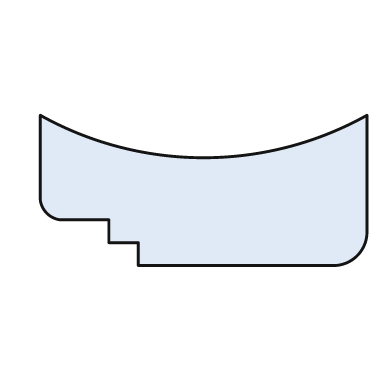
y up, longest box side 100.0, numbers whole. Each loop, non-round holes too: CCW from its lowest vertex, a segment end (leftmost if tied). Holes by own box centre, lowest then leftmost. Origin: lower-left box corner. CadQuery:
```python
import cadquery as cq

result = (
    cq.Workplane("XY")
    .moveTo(30.0, 0.0)
    .lineTo(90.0, 0.0)
    .threePointArc((97.0, 3.0), (100.0, 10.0))
    .lineTo(100.0, 46.0)
    .threePointArc((50.0, 33.0), (0.0, 46.0))
    .lineTo(0.0, 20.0)
    .threePointArc((2.0, 16.0), (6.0, 14.0))
    .lineTo(21.0, 14.0)
    .lineTo(21.0, 7.0)
    .lineTo(30.0, 7.0)
    .close()
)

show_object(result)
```